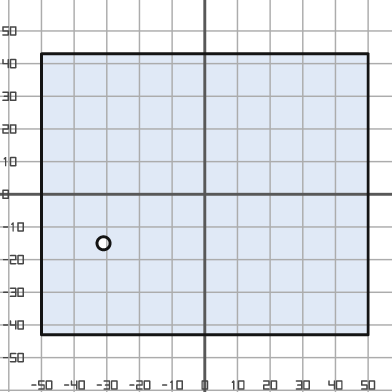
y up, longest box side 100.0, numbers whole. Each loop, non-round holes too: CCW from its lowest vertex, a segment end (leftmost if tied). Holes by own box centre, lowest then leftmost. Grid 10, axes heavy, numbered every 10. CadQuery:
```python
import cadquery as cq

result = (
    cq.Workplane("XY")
    .moveTo(-50.0, -43.0)
    .lineTo(50.0, -43.0)
    .lineTo(50.0, 43.0)
    .lineTo(-50.0, 43.0)
    .close()
    .moveTo(-31.0, -15.0)
    .circle(2.0)
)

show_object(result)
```